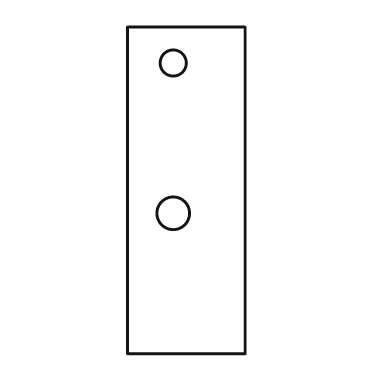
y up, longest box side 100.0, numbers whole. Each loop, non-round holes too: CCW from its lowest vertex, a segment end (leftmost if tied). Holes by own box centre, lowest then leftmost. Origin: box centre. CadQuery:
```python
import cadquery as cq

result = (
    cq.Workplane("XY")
    .moveTo(-18.0, -50.0)
    .lineTo(18.0, -50.0)
    .lineTo(18.0, 50.0)
    .lineTo(-18.0, 50.0)
    .close()
    .moveTo(-4.0, -7.0)
    .circle(5.0)
    .moveTo(-4.0, 39.0)
    .circle(4.0)
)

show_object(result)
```